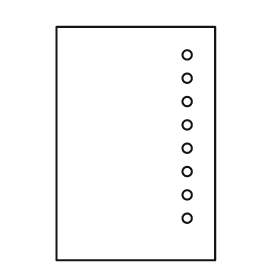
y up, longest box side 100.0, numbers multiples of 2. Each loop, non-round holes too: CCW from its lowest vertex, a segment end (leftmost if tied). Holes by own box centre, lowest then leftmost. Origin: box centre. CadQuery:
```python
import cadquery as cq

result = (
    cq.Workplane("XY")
    .moveTo(-34.0, -50.0)
    .lineTo(34.0, -50.0)
    .lineTo(34.0, 50.0)
    .lineTo(-34.0, 50.0)
    .close()
    .moveTo(22.0, -32.0)
    .circle(2.0)
    .moveTo(22.0, -22.0)
    .circle(2.0)
    .moveTo(22.0, -12.0)
    .circle(2.0)
    .moveTo(22.0, -2.0)
    .circle(2.0)
    .moveTo(22.0, 8.0)
    .circle(2.0)
    .moveTo(22.0, 18.0)
    .circle(2.0)
    .moveTo(22.0, 28.0)
    .circle(2.0)
    .moveTo(22.0, 38.0)
    .circle(2.0)
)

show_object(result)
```